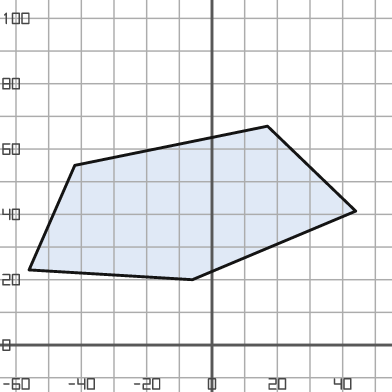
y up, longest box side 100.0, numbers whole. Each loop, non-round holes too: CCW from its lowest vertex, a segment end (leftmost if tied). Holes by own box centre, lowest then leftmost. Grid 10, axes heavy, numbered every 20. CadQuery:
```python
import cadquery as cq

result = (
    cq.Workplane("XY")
    .moveTo(-6.0, 20.0)
    .lineTo(44.0, 41.0)
    .lineTo(17.0, 67.0)
    .lineTo(-42.0, 55.0)
    .lineTo(-56.0, 23.0)
    .close()
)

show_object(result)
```